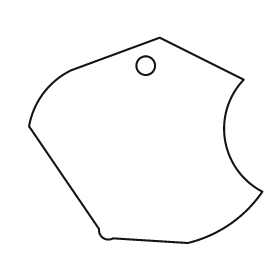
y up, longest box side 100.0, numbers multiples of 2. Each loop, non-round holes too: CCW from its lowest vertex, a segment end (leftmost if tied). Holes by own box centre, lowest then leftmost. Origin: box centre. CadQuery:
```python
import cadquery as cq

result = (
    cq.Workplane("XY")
    .moveTo(18.0, -44.0)
    .threePointArc((36.0, -36.0), (50.0, -22.0))
    .threePointArc((34.0, 0.0), (42.0, 26.0))
    .lineTo(6.0, 44.0)
    .lineTo(-32.0, 30.0)
    .threePointArc((-44.0, 20.0), (-50.0, 6.0))
    .lineTo(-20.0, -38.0)
    .threePointArc((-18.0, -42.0), (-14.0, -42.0))
    .close()
    .moveTo(0.0, 32.0)
    .circle(4.0)
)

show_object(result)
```